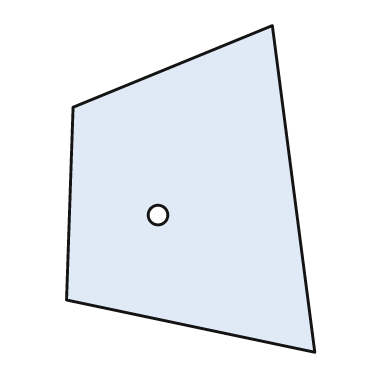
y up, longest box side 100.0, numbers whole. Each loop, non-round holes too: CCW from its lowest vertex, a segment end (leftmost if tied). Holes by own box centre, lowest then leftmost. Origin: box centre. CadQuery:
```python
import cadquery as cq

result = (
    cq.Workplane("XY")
    .moveTo(38.0, -50.0)
    .lineTo(25.0, 50.0)
    .lineTo(-36.0, 25.0)
    .lineTo(-38.0, -34.0)
    .close()
    .moveTo(-10.0, -8.0)
    .circle(3.0)
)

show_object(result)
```